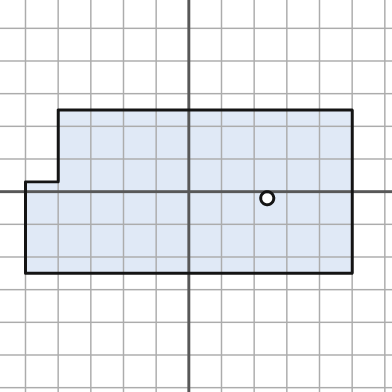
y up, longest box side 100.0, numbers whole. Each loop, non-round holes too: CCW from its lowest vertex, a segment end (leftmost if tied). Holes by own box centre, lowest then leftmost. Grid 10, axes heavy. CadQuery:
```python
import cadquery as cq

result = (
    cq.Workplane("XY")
    .moveTo(-50.0, -25.0)
    .lineTo(50.0, -25.0)
    .lineTo(50.0, 25.0)
    .lineTo(-40.0, 25.0)
    .lineTo(-40.0, 3.0)
    .lineTo(-50.0, 3.0)
    .close()
    .moveTo(24.0, -2.0)
    .circle(2.0)
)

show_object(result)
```